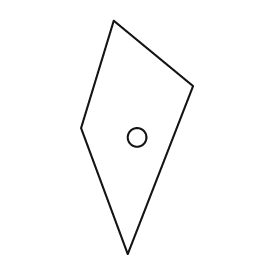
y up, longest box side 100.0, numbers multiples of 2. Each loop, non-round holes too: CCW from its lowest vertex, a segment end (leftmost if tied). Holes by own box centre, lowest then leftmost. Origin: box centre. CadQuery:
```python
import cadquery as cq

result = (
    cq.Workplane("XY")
    .moveTo(-4.0, -50.0)
    .lineTo(24.0, 22.0)
    .lineTo(-10.0, 50.0)
    .lineTo(-24.0, 4.0)
    .close()
    .moveTo(0.0, 0.0)
    .circle(4.0)
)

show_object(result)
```